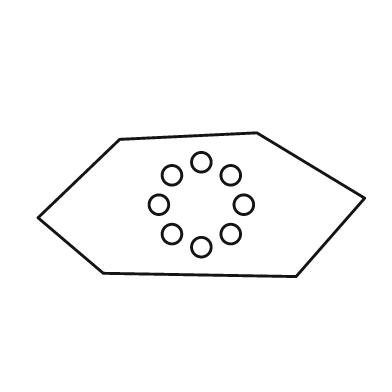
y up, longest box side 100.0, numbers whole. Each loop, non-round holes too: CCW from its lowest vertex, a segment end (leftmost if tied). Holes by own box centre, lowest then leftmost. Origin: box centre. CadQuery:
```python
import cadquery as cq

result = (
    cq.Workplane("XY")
    .moveTo(29.0, -22.0)
    .lineTo(50.0, 2.0)
    .lineTo(17.0, 22.0)
    .lineTo(-25.0, 20.0)
    .lineTo(-50.0, -4.0)
    .lineTo(-30.0, -21.0)
    .close()
    .moveTo(0.0, -13.0)
    .circle(3.0)
    .moveTo(-9.0, -9.0)
    .circle(3.0)
    .moveTo(9.0, -9.0)
    .circle(3.0)
    .moveTo(-13.0, 0.0)
    .circle(3.0)
    .moveTo(13.0, 0.0)
    .circle(3.0)
    .moveTo(-9.0, 9.0)
    .circle(3.0)
    .moveTo(9.0, 9.0)
    .circle(3.0)
    .moveTo(0.0, 13.0)
    .circle(3.0)
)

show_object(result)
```